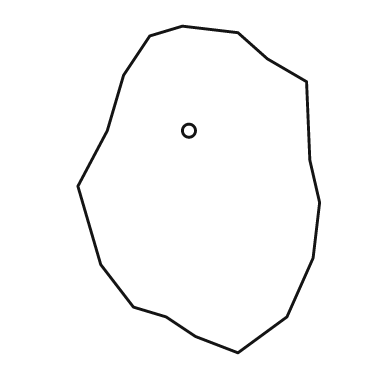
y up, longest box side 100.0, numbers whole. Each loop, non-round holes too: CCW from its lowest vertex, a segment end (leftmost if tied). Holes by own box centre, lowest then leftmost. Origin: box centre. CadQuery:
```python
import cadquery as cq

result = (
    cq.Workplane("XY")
    .moveTo(12.0, -50.0)
    .lineTo(27.0, -39.0)
    .lineTo(35.0, -21.0)
    .lineTo(37.0, -4.0)
    .lineTo(34.0, 9.0)
    .lineTo(33.0, 33.0)
    .lineTo(21.0, 40.0)
    .lineTo(12.0, 48.0)
    .lineTo(-5.0, 50.0)
    .lineTo(-15.0, 47.0)
    .lineTo(-23.0, 35.0)
    .lineTo(-28.0, 18.0)
    .lineTo(-37.0, 1.0)
    .lineTo(-30.0, -23.0)
    .lineTo(-20.0, -36.0)
    .lineTo(-10.0, -39.0)
    .lineTo(-1.0, -45.0)
    .close()
    .moveTo(-3.0, 18.0)
    .circle(2.0)
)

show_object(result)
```